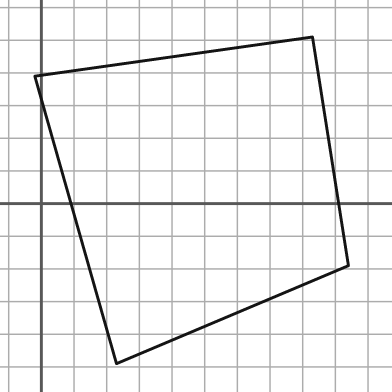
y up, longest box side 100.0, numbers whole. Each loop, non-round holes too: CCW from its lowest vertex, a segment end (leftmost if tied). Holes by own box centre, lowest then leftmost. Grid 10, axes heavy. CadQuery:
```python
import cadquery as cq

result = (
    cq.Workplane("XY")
    .moveTo(23.0, -49.0)
    .lineTo(94.0, -19.0)
    .lineTo(83.0, 51.0)
    .lineTo(-2.0, 39.0)
    .close()
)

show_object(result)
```